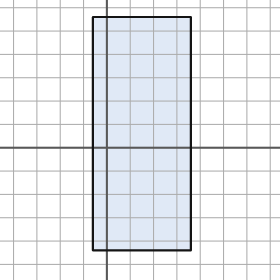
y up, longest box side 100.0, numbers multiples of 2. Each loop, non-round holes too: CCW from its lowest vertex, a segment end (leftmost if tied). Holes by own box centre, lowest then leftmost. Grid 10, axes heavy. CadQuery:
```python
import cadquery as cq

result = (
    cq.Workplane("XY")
    .moveTo(-6.0, -44.0)
    .lineTo(36.0, -44.0)
    .lineTo(36.0, 56.0)
    .lineTo(-6.0, 56.0)
    .close()
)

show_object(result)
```